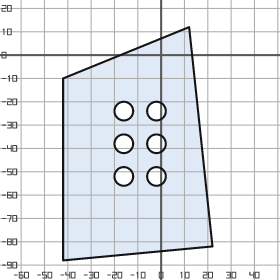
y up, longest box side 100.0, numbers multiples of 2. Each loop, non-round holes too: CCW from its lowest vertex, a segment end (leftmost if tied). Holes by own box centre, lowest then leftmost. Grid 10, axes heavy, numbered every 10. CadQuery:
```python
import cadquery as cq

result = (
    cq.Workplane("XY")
    .moveTo(-42.0, -88.0)
    .lineTo(22.0, -82.0)
    .lineTo(12.0, 12.0)
    .lineTo(-42.0, -10.0)
    .close()
    .moveTo(-16.0, -52.0)
    .circle(4.0)
    .moveTo(-2.0, -52.0)
    .circle(4.0)
    .moveTo(-16.0, -38.0)
    .circle(4.0)
    .moveTo(-2.0, -38.0)
    .circle(4.0)
    .moveTo(-16.0, -24.0)
    .circle(4.0)
    .moveTo(-2.0, -24.0)
    .circle(4.0)
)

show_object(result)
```